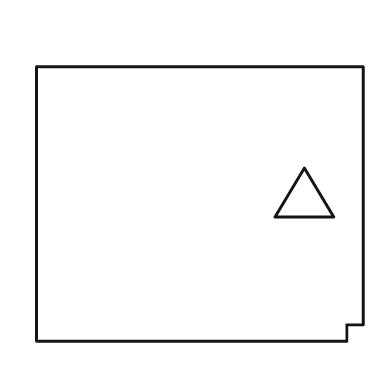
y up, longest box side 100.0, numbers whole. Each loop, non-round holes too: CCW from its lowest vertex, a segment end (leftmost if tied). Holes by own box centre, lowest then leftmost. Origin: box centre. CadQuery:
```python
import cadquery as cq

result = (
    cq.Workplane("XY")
    .moveTo(-50.0, -42.0)
    .lineTo(45.0, -42.0)
    .lineTo(45.0, -37.0)
    .lineTo(50.0, -37.0)
    .lineTo(50.0, 42.0)
    .lineTo(-50.0, 42.0)
    .close()
    .moveTo(23.0, -4.0)
    .lineTo(41.0, -4.0)
    .lineTo(32.0, 11.0)
    .close()
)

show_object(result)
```